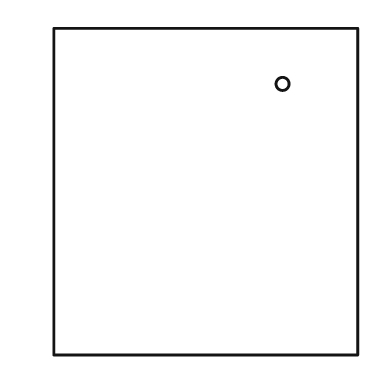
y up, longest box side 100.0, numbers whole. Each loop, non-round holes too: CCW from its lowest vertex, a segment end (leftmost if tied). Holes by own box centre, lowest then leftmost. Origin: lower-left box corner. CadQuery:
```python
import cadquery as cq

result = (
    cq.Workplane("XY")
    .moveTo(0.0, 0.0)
    .lineTo(93.0, 0.0)
    .lineTo(93.0, 100.0)
    .lineTo(0.0, 100.0)
    .close()
    .moveTo(70.0, 83.0)
    .circle(2.0)
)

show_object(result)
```